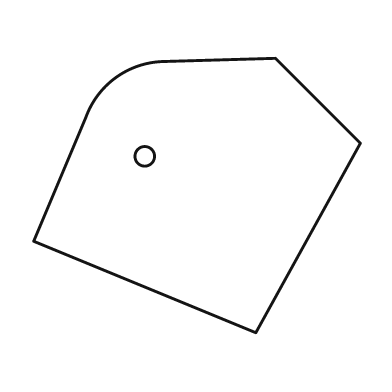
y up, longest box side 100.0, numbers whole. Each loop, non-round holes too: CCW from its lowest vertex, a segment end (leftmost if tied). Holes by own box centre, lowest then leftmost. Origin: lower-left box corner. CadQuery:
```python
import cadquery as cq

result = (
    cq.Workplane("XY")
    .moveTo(68.0, 0.0)
    .lineTo(100.0, 58.0)
    .lineTo(74.0, 84.0)
    .lineTo(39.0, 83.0)
    .threePointArc((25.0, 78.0), (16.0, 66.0))
    .lineTo(0.0, 28.0)
    .close()
    .moveTo(34.0, 54.0)
    .circle(3.0)
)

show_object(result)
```